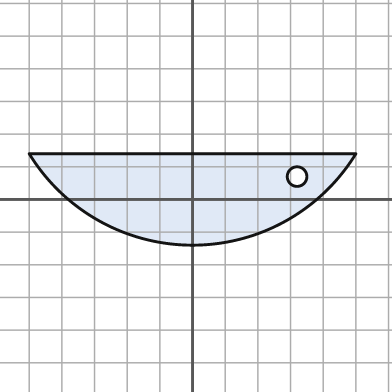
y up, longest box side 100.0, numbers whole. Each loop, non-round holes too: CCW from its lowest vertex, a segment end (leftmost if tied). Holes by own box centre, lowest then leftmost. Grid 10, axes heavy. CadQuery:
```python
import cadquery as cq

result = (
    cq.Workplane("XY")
    .moveTo(-50.0, 14.0)
    .threePointArc((0.0, -14.0), (50.0, 14.0))
    .close()
    .moveTo(32.0, 7.0)
    .circle(3.0)
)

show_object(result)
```